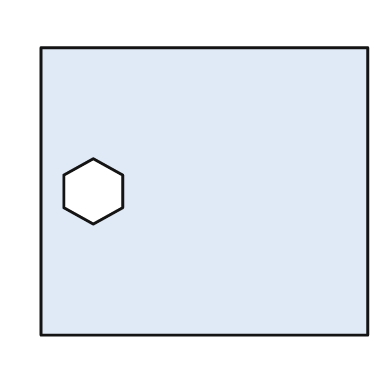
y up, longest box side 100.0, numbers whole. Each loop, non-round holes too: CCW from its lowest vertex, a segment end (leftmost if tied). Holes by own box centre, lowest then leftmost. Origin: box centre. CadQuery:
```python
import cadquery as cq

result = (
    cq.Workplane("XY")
    .moveTo(-50.0, -44.0)
    .lineTo(50.0, -44.0)
    .lineTo(50.0, 44.0)
    .lineTo(-50.0, 44.0)
    .close()
    .moveTo(-34.0, -10.0)
    .lineTo(-25.0, -5.0)
    .lineTo(-25.0, 5.0)
    .lineTo(-34.0, 10.0)
    .lineTo(-43.0, 5.0)
    .lineTo(-43.0, -5.0)
    .close()
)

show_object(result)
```